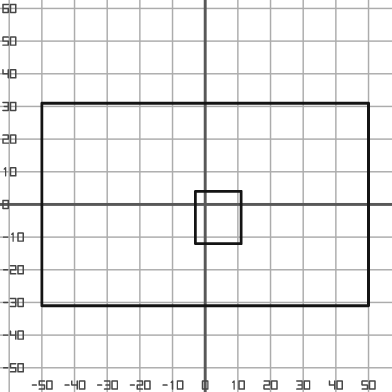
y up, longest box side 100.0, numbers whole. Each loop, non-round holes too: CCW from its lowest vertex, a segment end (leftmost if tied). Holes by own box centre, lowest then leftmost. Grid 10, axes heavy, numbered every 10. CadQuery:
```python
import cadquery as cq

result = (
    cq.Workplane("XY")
    .moveTo(-50.0, -31.0)
    .lineTo(50.0, -31.0)
    .lineTo(50.0, 31.0)
    .lineTo(-50.0, 31.0)
    .close()
    .moveTo(-3.0, -12.0)
    .lineTo(11.0, -12.0)
    .lineTo(11.0, 4.0)
    .lineTo(-3.0, 4.0)
    .close()
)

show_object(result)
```